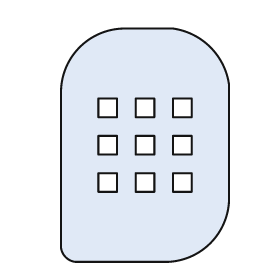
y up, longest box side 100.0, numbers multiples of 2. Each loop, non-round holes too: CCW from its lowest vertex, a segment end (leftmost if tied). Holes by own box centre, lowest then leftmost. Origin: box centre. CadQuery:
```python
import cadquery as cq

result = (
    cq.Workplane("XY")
    .moveTo(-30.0, -50.0)
    .lineTo(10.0, -50.0)
    .threePointArc((28.0, -42.0), (36.0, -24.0))
    .lineTo(36.0, 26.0)
    .threePointArc((28.0, 42.0), (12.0, 50.0))
    .lineTo(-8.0, 50.0)
    .threePointArc((-28.0, 42.0), (-36.0, 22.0))
    .lineTo(-36.0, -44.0)
    .threePointArc((-34.0, -48.0), (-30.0, -50.0))
    .close()
    .moveTo(-20.0, -20.0)
    .lineTo(-12.0, -20.0)
    .lineTo(-12.0, -12.0)
    .lineTo(-20.0, -12.0)
    .close()
    .moveTo(-4.0, -20.0)
    .lineTo(4.0, -20.0)
    .lineTo(4.0, -12.0)
    .lineTo(-4.0, -12.0)
    .close()
    .moveTo(12.0, -20.0)
    .lineTo(20.0, -20.0)
    .lineTo(20.0, -12.0)
    .lineTo(12.0, -12.0)
    .close()
    .moveTo(-20.0, -4.0)
    .lineTo(-12.0, -4.0)
    .lineTo(-12.0, 4.0)
    .lineTo(-20.0, 4.0)
    .close()
    .moveTo(-4.0, -4.0)
    .lineTo(4.0, -4.0)
    .lineTo(4.0, 4.0)
    .lineTo(-4.0, 4.0)
    .close()
    .moveTo(12.0, -4.0)
    .lineTo(20.0, -4.0)
    .lineTo(20.0, 4.0)
    .lineTo(12.0, 4.0)
    .close()
    .moveTo(-20.0, 12.0)
    .lineTo(-12.0, 12.0)
    .lineTo(-12.0, 20.0)
    .lineTo(-20.0, 20.0)
    .close()
    .moveTo(-4.0, 12.0)
    .lineTo(4.0, 12.0)
    .lineTo(4.0, 20.0)
    .lineTo(-4.0, 20.0)
    .close()
    .moveTo(12.0, 12.0)
    .lineTo(20.0, 12.0)
    .lineTo(20.0, 20.0)
    .lineTo(12.0, 20.0)
    .close()
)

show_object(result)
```